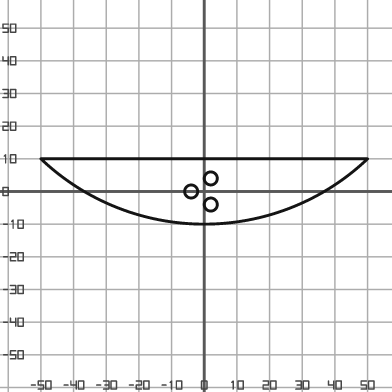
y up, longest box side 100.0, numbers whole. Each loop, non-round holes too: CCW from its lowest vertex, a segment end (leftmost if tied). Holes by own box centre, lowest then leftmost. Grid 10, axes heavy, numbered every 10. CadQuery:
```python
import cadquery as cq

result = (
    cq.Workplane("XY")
    .moveTo(-50.0, 10.0)
    .threePointArc((0.0, -10.0), (50.0, 10.0))
    .close()
    .moveTo(2.0, -4.0)
    .circle(2.0)
    .moveTo(-4.0, 0.0)
    .circle(2.0)
    .moveTo(2.0, 4.0)
    .circle(2.0)
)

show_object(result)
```